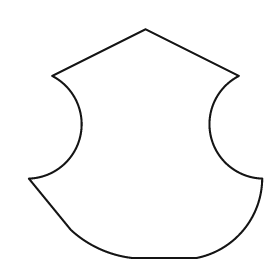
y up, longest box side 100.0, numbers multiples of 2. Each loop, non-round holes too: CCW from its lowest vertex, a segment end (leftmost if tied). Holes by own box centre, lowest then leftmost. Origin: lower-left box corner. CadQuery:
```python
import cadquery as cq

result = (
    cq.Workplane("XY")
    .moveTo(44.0, 0.0)
    .lineTo(72.0, 0.0)
    .threePointArc((92.0, 12.0), (100.0, 34.0))
    .threePointArc((78.0, 52.0), (90.0, 78.0))
    .lineTo(50.0, 98.0)
    .lineTo(10.0, 78.0)
    .threePointArc((22.0, 52.0), (0.0, 34.0))
    .lineTo(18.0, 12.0)
    .threePointArc((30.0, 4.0), (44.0, 0.0))
    .close()
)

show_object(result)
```